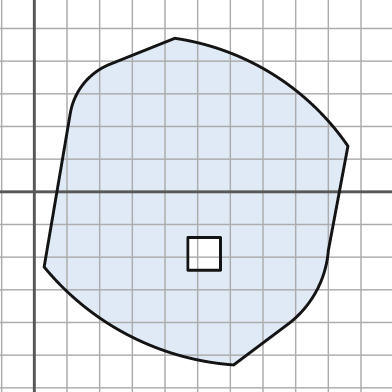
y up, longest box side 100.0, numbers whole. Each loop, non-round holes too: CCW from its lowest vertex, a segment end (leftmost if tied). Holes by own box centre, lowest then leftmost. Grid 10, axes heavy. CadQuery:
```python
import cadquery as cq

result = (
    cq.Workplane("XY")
    .moveTo(61.0, -53.0)
    .lineTo(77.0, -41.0)
    .threePointArc((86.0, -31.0), (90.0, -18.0))
    .lineTo(96.0, 14.0)
    .threePointArc((73.0, 36.0), (43.0, 47.0))
    .lineTo(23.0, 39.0)
    .threePointArc((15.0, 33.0), (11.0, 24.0))
    .lineTo(3.0, -23.0)
    .threePointArc((29.0, -44.0), (61.0, -53.0))
    .close()
    .moveTo(47.0, -24.0)
    .lineTo(57.0, -24.0)
    .lineTo(57.0, -14.0)
    .lineTo(47.0, -14.0)
    .close()
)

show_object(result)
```